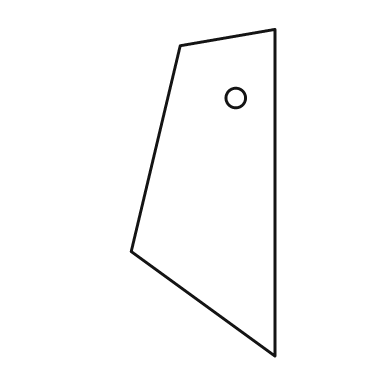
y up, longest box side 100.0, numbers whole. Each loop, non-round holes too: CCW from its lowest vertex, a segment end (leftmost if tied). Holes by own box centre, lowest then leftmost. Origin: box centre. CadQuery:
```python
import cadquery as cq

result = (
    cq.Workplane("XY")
    .moveTo(22.0, -50.0)
    .lineTo(22.0, 50.0)
    .lineTo(-7.0, 45.0)
    .lineTo(-22.0, -18.0)
    .close()
    .moveTo(10.0, 29.0)
    .circle(3.0)
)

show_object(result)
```